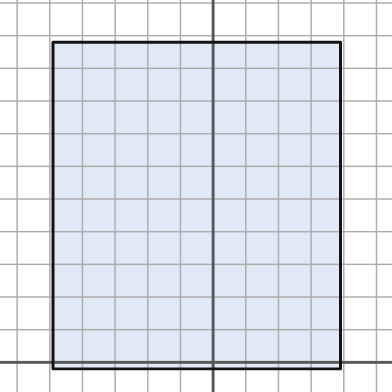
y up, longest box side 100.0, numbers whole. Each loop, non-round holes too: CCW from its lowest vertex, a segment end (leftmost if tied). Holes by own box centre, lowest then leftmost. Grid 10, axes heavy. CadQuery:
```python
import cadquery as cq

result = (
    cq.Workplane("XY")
    .moveTo(-49.0, -2.0)
    .lineTo(39.0, -2.0)
    .lineTo(39.0, 98.0)
    .lineTo(-49.0, 98.0)
    .close()
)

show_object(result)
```